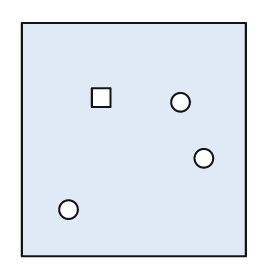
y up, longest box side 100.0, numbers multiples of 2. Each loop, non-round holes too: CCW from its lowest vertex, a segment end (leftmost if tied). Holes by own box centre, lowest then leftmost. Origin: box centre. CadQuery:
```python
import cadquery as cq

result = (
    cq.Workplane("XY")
    .moveTo(-48.0, -50.0)
    .lineTo(48.0, -50.0)
    .lineTo(48.0, 50.0)
    .lineTo(-48.0, 50.0)
    .close()
    .moveTo(-28.0, -30.0)
    .circle(4.0)
    .moveTo(30.0, -8.0)
    .circle(4.0)
    .moveTo(20.0, 16.0)
    .circle(4.0)
    .moveTo(-18.0, 14.0)
    .lineTo(-10.0, 14.0)
    .lineTo(-10.0, 22.0)
    .lineTo(-18.0, 22.0)
    .close()
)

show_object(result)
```